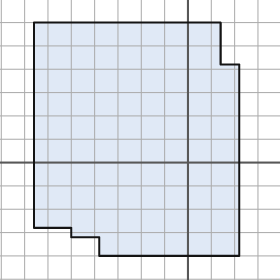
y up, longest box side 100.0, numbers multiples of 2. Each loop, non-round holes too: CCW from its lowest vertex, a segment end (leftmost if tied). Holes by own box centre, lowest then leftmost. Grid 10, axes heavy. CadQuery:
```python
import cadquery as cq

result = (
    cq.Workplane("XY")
    .moveTo(-38.0, -40.0)
    .lineTo(22.0, -40.0)
    .lineTo(22.0, 42.0)
    .lineTo(14.0, 42.0)
    .lineTo(14.0, 60.0)
    .lineTo(-66.0, 60.0)
    .lineTo(-66.0, -28.0)
    .lineTo(-50.0, -28.0)
    .lineTo(-50.0, -32.0)
    .lineTo(-38.0, -32.0)
    .close()
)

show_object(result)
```